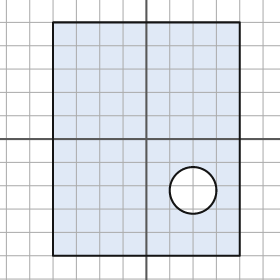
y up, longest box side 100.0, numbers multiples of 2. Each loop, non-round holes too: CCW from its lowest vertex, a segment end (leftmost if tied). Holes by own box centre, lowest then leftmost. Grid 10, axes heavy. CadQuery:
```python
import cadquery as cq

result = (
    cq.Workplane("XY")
    .moveTo(-40.0, -50.0)
    .lineTo(40.0, -50.0)
    .lineTo(40.0, 50.0)
    .lineTo(-40.0, 50.0)
    .close()
    .moveTo(20.0, -22.0)
    .circle(10.0)
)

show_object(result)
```